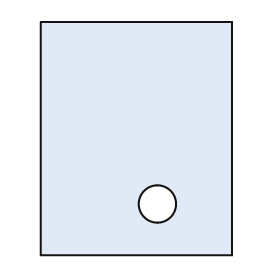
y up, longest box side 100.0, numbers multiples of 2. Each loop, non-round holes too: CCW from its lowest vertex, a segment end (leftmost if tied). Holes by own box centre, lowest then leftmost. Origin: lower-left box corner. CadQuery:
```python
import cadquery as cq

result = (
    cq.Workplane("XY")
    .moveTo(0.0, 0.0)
    .lineTo(82.0, 0.0)
    .lineTo(82.0, 100.0)
    .lineTo(0.0, 100.0)
    .close()
    .moveTo(50.0, 22.0)
    .circle(8.0)
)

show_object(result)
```